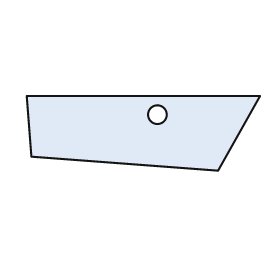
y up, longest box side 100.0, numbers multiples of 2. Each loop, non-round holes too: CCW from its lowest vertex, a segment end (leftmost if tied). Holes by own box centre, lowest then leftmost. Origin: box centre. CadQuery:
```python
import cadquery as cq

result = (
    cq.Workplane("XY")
    .moveTo(32.0, -16.0)
    .lineTo(50.0, 16.0)
    .lineTo(-50.0, 16.0)
    .lineTo(-48.0, -10.0)
    .close()
    .moveTo(6.0, 8.0)
    .circle(4.0)
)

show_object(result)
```